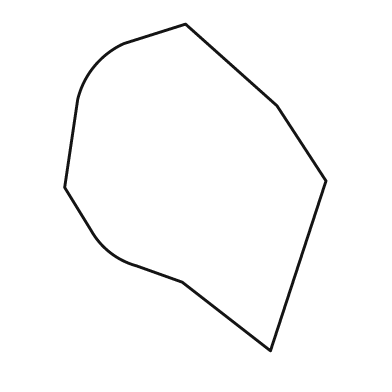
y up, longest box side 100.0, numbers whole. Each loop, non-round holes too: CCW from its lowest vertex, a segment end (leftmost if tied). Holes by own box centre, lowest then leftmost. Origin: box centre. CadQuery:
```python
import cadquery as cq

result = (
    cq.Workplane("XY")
    .moveTo(23.0, -50.0)
    .lineTo(40.0, 2.0)
    .lineTo(25.0, 25.0)
    .lineTo(-3.0, 50.0)
    .lineTo(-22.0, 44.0)
    .threePointArc((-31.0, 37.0), (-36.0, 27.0))
    .lineTo(-40.0, 0.0)
    .lineTo(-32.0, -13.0)
    .threePointArc((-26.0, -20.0), (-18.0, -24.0))
    .lineTo(-4.0, -29.0)
    .close()
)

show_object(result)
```